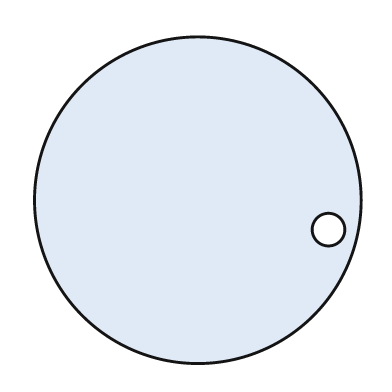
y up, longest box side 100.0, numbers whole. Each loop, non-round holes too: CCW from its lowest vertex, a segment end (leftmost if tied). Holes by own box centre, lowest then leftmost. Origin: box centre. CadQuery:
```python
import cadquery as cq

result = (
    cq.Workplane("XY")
    .moveTo(0.0, 0.0)
    .circle(50.0)
    .moveTo(40.0, -9.0)
    .circle(5.0)
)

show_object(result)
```